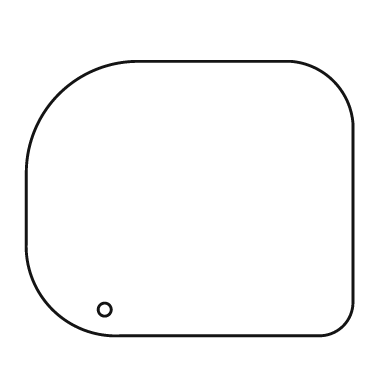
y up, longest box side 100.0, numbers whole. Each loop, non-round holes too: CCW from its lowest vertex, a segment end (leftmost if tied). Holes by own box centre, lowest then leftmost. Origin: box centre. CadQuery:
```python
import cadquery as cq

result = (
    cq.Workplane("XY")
    .moveTo(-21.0, -42.0)
    .lineTo(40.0, -42.0)
    .threePointArc((47.0, -39.0), (50.0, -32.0))
    .lineTo(50.0, 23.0)
    .threePointArc((44.0, 36.0), (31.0, 42.0))
    .lineTo(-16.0, 42.0)
    .threePointArc((-40.0, 32.0), (-50.0, 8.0))
    .lineTo(-50.0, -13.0)
    .threePointArc((-42.0, -34.0), (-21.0, -42.0))
    .close()
    .moveTo(-26.0, -34.0)
    .circle(2.0)
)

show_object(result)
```